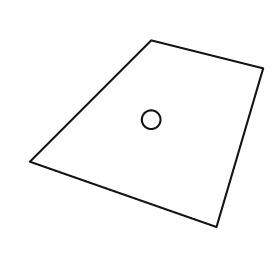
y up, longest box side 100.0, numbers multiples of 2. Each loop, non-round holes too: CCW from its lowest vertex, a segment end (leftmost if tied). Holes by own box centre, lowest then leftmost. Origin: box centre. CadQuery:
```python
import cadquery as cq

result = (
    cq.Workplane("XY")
    .moveTo(30.0, -40.0)
    .lineTo(50.0, 28.0)
    .lineTo(2.0, 40.0)
    .lineTo(-50.0, -12.0)
    .close()
    .moveTo(2.0, 6.0)
    .circle(4.0)
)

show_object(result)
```